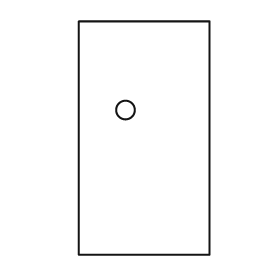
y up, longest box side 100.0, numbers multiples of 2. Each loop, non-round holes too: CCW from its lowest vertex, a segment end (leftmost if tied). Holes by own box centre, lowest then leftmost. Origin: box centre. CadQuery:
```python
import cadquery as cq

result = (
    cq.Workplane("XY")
    .moveTo(-28.0, -50.0)
    .lineTo(28.0, -50.0)
    .lineTo(28.0, 50.0)
    .lineTo(-28.0, 50.0)
    .close()
    .moveTo(-8.0, 12.0)
    .circle(4.0)
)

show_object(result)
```